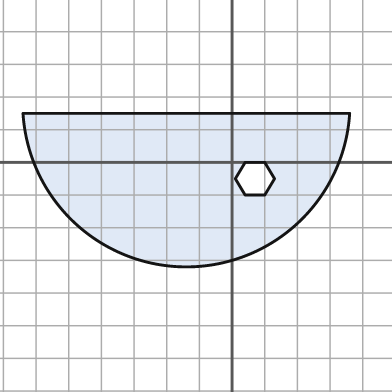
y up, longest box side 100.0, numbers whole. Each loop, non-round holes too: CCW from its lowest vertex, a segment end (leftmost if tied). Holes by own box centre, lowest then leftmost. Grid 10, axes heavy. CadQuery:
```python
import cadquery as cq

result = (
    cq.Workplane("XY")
    .moveTo(-64.0, 15.0)
    .threePointArc((-14.0, -32.0), (36.0, 15.0))
    .close()
    .moveTo(4.0, -10.0)
    .lineTo(10.0, -10.0)
    .lineTo(13.0, -5.0)
    .lineTo(10.0, 0.0)
    .lineTo(4.0, 0.0)
    .lineTo(1.0, -5.0)
    .close()
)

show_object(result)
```